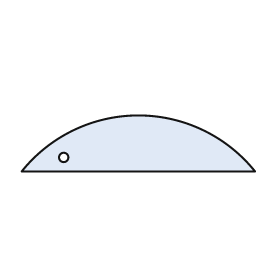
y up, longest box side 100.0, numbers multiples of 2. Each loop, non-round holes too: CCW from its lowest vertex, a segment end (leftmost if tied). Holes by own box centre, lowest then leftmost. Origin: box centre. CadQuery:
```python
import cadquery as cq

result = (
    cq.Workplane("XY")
    .moveTo(-50.0, -12.0)
    .lineTo(50.0, -12.0)
    .threePointArc((0.0, 12.0), (-50.0, -12.0))
    .close()
    .moveTo(-32.0, -6.0)
    .circle(2.0)
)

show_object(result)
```